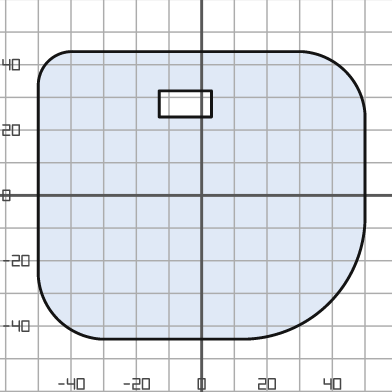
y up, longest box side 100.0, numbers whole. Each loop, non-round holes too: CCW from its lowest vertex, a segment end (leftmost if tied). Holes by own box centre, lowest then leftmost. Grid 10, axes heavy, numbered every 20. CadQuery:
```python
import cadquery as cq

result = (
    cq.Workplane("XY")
    .moveTo(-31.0, -44.0)
    .lineTo(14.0, -44.0)
    .threePointArc((39.0, -33.0), (50.0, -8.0))
    .lineTo(50.0, 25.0)
    .threePointArc((44.0, 38.0), (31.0, 44.0))
    .lineTo(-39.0, 44.0)
    .threePointArc((-47.0, 41.0), (-50.0, 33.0))
    .lineTo(-50.0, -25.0)
    .threePointArc((-44.0, -38.0), (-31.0, -44.0))
    .close()
    .moveTo(-13.0, 24.0)
    .lineTo(3.0, 24.0)
    .lineTo(3.0, 32.0)
    .lineTo(-13.0, 32.0)
    .close()
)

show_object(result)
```